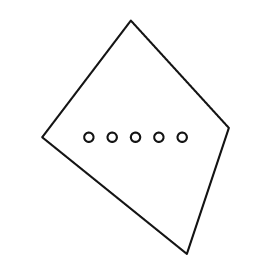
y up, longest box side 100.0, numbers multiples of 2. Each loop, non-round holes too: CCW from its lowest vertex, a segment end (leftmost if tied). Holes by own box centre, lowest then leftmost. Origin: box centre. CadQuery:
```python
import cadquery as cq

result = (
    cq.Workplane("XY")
    .moveTo(22.0, -50.0)
    .lineTo(40.0, 4.0)
    .lineTo(-2.0, 50.0)
    .lineTo(-40.0, 0.0)
    .close()
    .moveTo(-20.0, 0.0)
    .circle(2.0)
    .moveTo(-10.0, 0.0)
    .circle(2.0)
    .moveTo(0.0, 0.0)
    .circle(2.0)
    .moveTo(10.0, 0.0)
    .circle(2.0)
    .moveTo(20.0, 0.0)
    .circle(2.0)
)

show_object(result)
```